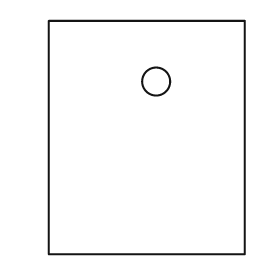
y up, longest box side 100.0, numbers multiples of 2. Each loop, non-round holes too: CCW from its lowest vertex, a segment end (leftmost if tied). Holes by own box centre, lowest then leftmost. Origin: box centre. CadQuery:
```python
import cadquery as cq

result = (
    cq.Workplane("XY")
    .moveTo(-42.0, -50.0)
    .lineTo(42.0, -50.0)
    .lineTo(42.0, 50.0)
    .lineTo(-42.0, 50.0)
    .close()
    .moveTo(4.0, 24.0)
    .circle(6.0)
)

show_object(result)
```